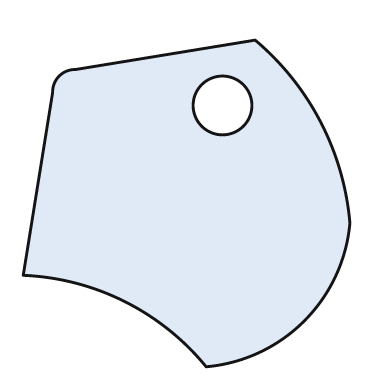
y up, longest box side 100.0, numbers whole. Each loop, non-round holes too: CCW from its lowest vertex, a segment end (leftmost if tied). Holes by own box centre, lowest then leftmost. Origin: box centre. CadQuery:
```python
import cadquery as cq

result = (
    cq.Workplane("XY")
    .moveTo(6.0, -50.0)
    .threePointArc((36.0, -36.0), (50.0, -6.0))
    .threePointArc((41.0, 25.0), (21.0, 50.0))
    .lineTo(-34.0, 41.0)
    .threePointArc((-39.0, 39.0), (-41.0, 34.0))
    .lineTo(-50.0, -22.0)
    .threePointArc((-19.0, -30.0), (6.0, -50.0))
    .close()
    .moveTo(11.0, 30.0)
    .circle(9.0)
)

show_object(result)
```